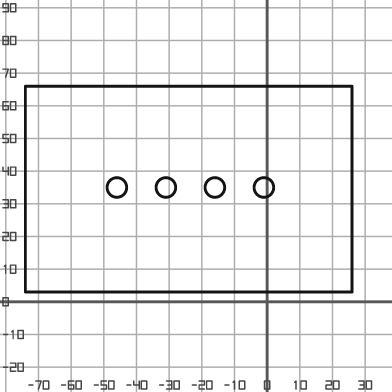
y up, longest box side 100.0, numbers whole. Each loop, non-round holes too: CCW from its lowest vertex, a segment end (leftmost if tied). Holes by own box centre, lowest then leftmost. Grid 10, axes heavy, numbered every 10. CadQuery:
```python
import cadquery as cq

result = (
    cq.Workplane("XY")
    .moveTo(-74.0, 3.0)
    .lineTo(26.0, 3.0)
    .lineTo(26.0, 66.0)
    .lineTo(-74.0, 66.0)
    .close()
    .moveTo(-46.0, 35.0)
    .circle(3.0)
    .moveTo(-31.0, 35.0)
    .circle(3.0)
    .moveTo(-16.0, 35.0)
    .circle(3.0)
    .moveTo(-1.0, 35.0)
    .circle(3.0)
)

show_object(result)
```